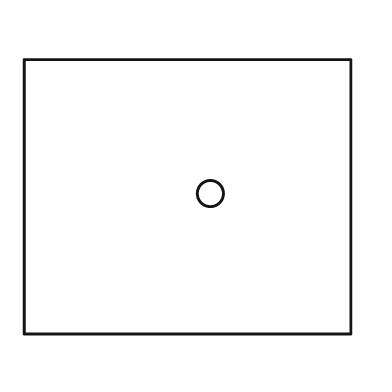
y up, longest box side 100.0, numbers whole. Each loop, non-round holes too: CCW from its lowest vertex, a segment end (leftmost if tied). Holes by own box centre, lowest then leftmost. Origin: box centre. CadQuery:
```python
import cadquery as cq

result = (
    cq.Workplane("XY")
    .moveTo(-50.0, -42.0)
    .lineTo(50.0, -42.0)
    .lineTo(50.0, 42.0)
    .lineTo(-50.0, 42.0)
    .close()
    .moveTo(7.0, 1.0)
    .circle(4.0)
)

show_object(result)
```